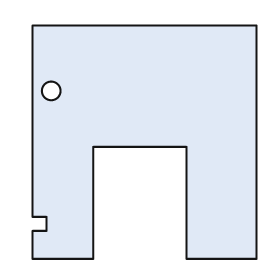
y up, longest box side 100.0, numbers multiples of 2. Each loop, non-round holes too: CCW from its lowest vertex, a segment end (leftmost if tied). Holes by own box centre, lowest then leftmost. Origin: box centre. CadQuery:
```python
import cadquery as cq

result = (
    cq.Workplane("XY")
    .moveTo(-48.0, -50.0)
    .lineTo(-22.0, -50.0)
    .lineTo(-22.0, -2.0)
    .lineTo(18.0, -2.0)
    .lineTo(18.0, -50.0)
    .lineTo(48.0, -50.0)
    .lineTo(48.0, 50.0)
    .lineTo(-48.0, 50.0)
    .lineTo(-48.0, -32.0)
    .lineTo(-42.0, -32.0)
    .lineTo(-42.0, -38.0)
    .lineTo(-48.0, -38.0)
    .close()
    .moveTo(-40.0, 22.0)
    .circle(4.0)
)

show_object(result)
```